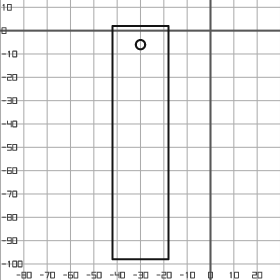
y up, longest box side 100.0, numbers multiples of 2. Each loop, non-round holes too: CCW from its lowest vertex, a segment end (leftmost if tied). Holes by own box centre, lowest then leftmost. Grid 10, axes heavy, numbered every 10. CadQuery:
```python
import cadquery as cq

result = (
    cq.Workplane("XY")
    .moveTo(-42.0, -98.0)
    .lineTo(-18.0, -98.0)
    .lineTo(-18.0, 2.0)
    .lineTo(-42.0, 2.0)
    .close()
    .moveTo(-30.0, -6.0)
    .circle(2.0)
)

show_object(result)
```